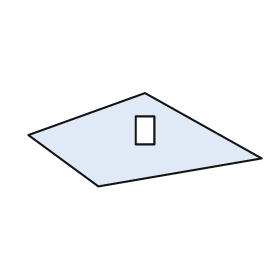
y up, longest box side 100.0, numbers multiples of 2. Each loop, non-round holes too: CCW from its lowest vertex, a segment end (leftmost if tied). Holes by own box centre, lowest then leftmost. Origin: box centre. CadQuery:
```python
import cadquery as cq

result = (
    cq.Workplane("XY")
    .moveTo(-20.0, -20.0)
    .lineTo(50.0, -8.0)
    .lineTo(0.0, 20.0)
    .lineTo(-50.0, 2.0)
    .close()
    .moveTo(-4.0, -2.0)
    .lineTo(4.0, -2.0)
    .lineTo(4.0, 10.0)
    .lineTo(-4.0, 10.0)
    .close()
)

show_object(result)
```